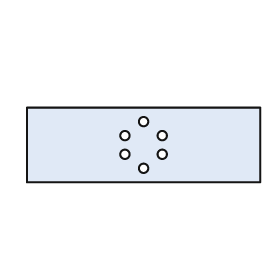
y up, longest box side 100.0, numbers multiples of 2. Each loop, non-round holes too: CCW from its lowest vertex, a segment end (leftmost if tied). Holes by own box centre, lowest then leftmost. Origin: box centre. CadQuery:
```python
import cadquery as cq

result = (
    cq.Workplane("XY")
    .moveTo(-50.0, -16.0)
    .lineTo(50.0, -16.0)
    .lineTo(50.0, 16.0)
    .lineTo(-50.0, 16.0)
    .close()
    .moveTo(0.0, -10.0)
    .circle(2.0)
    .moveTo(-8.0, -4.0)
    .circle(2.0)
    .moveTo(8.0, -4.0)
    .circle(2.0)
    .moveTo(-8.0, 4.0)
    .circle(2.0)
    .moveTo(8.0, 4.0)
    .circle(2.0)
    .moveTo(0.0, 10.0)
    .circle(2.0)
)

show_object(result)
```